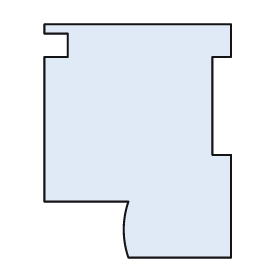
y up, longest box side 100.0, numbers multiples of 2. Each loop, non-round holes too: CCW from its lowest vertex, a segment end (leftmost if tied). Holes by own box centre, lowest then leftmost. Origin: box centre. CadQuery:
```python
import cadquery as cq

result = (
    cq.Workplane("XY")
    .moveTo(-4.0, -50.0)
    .lineTo(40.0, -50.0)
    .lineTo(40.0, -6.0)
    .lineTo(32.0, -6.0)
    .lineTo(32.0, 36.0)
    .lineTo(40.0, 36.0)
    .lineTo(40.0, 50.0)
    .lineTo(-40.0, 50.0)
    .lineTo(-40.0, 46.0)
    .lineTo(-30.0, 46.0)
    .lineTo(-30.0, 36.0)
    .lineTo(-40.0, 36.0)
    .lineTo(-40.0, -26.0)
    .lineTo(-4.0, -26.0)
    .threePointArc((-6.0, -38.0), (-4.0, -50.0))
    .close()
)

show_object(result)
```